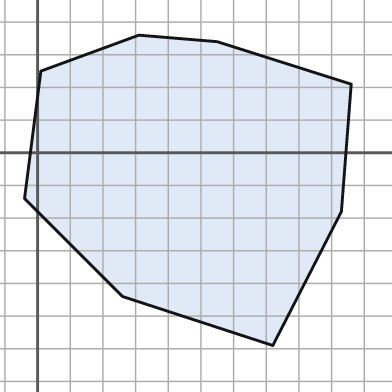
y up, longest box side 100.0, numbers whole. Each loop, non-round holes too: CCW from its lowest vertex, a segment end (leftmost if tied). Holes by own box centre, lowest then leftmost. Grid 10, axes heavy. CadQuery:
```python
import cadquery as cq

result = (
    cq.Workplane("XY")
    .moveTo(72.0, -59.0)
    .lineTo(93.0, -18.0)
    .lineTo(96.0, 21.0)
    .lineTo(55.0, 34.0)
    .lineTo(31.0, 36.0)
    .lineTo(1.0, 25.0)
    .lineTo(-4.0, -14.0)
    .lineTo(26.0, -44.0)
    .close()
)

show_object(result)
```